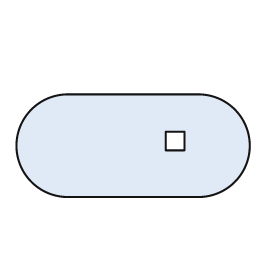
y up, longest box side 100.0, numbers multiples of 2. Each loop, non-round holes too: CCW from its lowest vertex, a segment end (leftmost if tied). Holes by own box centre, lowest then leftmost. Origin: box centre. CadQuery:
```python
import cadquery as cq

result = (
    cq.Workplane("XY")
    .moveTo(-28.0, -22.0)
    .lineTo(28.0, -22.0)
    .threePointArc((50.0, 0.0), (28.0, 22.0))
    .lineTo(-28.0, 22.0)
    .threePointArc((-50.0, 0.0), (-28.0, -22.0))
    .close()
    .moveTo(14.0, -2.0)
    .lineTo(22.0, -2.0)
    .lineTo(22.0, 6.0)
    .lineTo(14.0, 6.0)
    .close()
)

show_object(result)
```